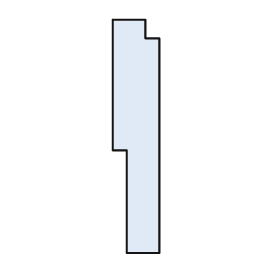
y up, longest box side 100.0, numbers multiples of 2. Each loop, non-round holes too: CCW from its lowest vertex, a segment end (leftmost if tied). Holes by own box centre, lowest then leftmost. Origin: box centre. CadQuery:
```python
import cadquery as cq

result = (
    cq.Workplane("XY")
    .moveTo(-4.0, -50.0)
    .lineTo(10.0, -50.0)
    .lineTo(10.0, 42.0)
    .lineTo(4.0, 42.0)
    .lineTo(4.0, 50.0)
    .lineTo(-10.0, 50.0)
    .lineTo(-10.0, -6.0)
    .lineTo(-4.0, -6.0)
    .close()
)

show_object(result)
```